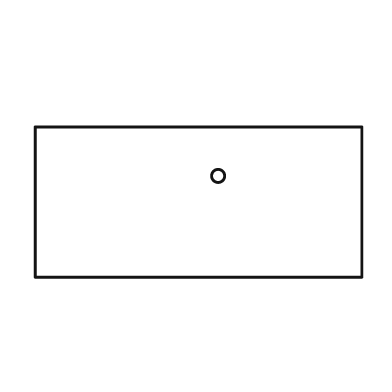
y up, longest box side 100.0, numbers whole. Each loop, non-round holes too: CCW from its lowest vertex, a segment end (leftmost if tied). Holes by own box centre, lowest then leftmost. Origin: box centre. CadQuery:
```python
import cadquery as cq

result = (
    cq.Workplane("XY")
    .moveTo(-50.0, -23.0)
    .lineTo(50.0, -23.0)
    .lineTo(50.0, 23.0)
    .lineTo(-50.0, 23.0)
    .close()
    .moveTo(6.0, 8.0)
    .circle(2.0)
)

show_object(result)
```